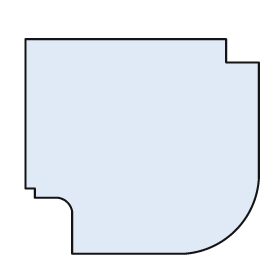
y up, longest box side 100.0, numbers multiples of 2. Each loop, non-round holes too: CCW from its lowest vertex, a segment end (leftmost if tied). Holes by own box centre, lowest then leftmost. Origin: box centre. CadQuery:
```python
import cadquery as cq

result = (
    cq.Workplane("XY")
    .moveTo(-30.0, -46.0)
    .lineTo(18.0, -46.0)
    .threePointArc((40.0, -36.0), (50.0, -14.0))
    .lineTo(50.0, 36.0)
    .lineTo(36.0, 36.0)
    .lineTo(36.0, 46.0)
    .lineTo(-50.0, 46.0)
    .lineTo(-50.0, -18.0)
    .lineTo(-46.0, -18.0)
    .lineTo(-46.0, -22.0)
    .lineTo(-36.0, -22.0)
    .threePointArc((-32.0, -24.0), (-30.0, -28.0))
    .close()
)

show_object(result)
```